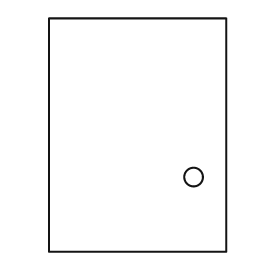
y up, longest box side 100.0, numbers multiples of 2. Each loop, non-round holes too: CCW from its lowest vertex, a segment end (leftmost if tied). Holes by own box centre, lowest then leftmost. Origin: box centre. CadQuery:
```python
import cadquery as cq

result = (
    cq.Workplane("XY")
    .moveTo(-38.0, -50.0)
    .lineTo(38.0, -50.0)
    .lineTo(38.0, 50.0)
    .lineTo(-38.0, 50.0)
    .close()
    .moveTo(24.0, -18.0)
    .circle(4.0)
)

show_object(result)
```